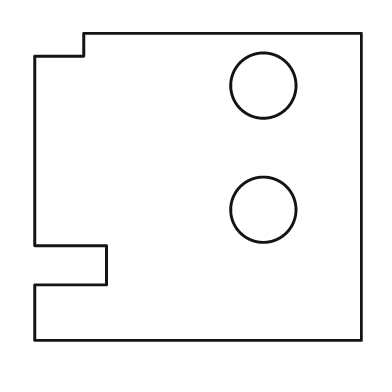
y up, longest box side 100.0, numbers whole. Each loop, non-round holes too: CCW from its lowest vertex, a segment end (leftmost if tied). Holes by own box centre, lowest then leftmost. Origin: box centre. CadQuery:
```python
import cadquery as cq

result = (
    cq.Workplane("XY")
    .moveTo(-50.0, -47.0)
    .lineTo(50.0, -47.0)
    .lineTo(50.0, 47.0)
    .lineTo(-35.0, 47.0)
    .lineTo(-35.0, 40.0)
    .lineTo(-50.0, 40.0)
    .lineTo(-50.0, -18.0)
    .lineTo(-28.0, -18.0)
    .lineTo(-28.0, -30.0)
    .lineTo(-50.0, -30.0)
    .close()
    .moveTo(20.0, -7.0)
    .circle(10.0)
    .moveTo(20.0, 31.0)
    .circle(10.0)
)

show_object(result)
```